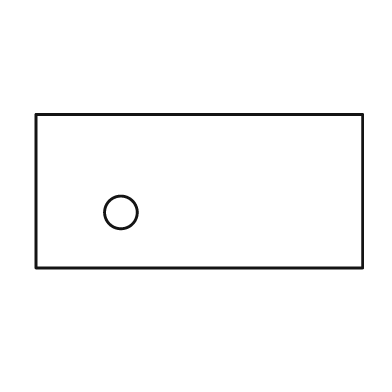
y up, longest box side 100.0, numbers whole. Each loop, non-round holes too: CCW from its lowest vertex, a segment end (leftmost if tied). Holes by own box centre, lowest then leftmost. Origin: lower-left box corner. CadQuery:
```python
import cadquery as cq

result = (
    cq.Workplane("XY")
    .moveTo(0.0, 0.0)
    .lineTo(100.0, 0.0)
    .lineTo(100.0, 47.0)
    .lineTo(0.0, 47.0)
    .close()
    .moveTo(26.0, 17.0)
    .circle(5.0)
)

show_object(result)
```